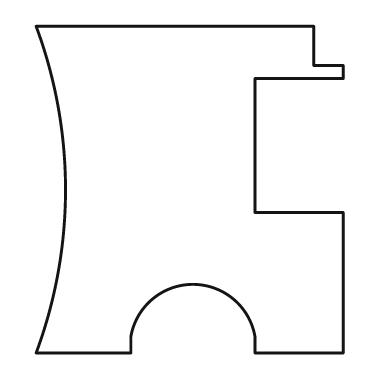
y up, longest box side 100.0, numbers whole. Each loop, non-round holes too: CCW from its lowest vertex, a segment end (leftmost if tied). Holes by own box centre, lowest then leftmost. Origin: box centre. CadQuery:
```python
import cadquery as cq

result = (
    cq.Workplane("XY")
    .moveTo(-47.0, -50.0)
    .lineTo(-18.0, -50.0)
    .lineTo(-18.0, -45.0)
    .threePointArc((1.0, -29.0), (20.0, -45.0))
    .lineTo(20.0, -50.0)
    .lineTo(47.0, -50.0)
    .lineTo(47.0, -7.0)
    .lineTo(20.0, -7.0)
    .lineTo(20.0, 34.0)
    .lineTo(47.0, 34.0)
    .lineTo(47.0, 38.0)
    .lineTo(38.0, 38.0)
    .lineTo(38.0, 50.0)
    .lineTo(-47.0, 50.0)
    .threePointArc((-38.0, 0.0), (-47.0, -50.0))
    .close()
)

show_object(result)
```